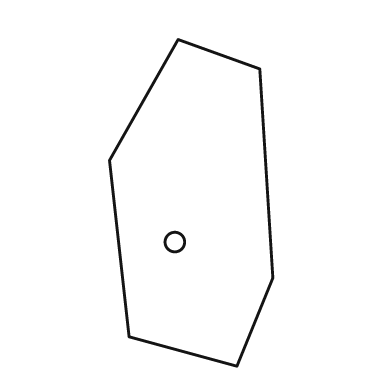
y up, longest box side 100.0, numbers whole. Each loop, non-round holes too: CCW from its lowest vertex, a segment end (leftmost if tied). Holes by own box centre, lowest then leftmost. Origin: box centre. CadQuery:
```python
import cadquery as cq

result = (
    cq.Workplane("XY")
    .moveTo(14.0, -50.0)
    .lineTo(25.0, -23.0)
    .lineTo(21.0, 41.0)
    .lineTo(-4.0, 50.0)
    .lineTo(-25.0, 13.0)
    .lineTo(-19.0, -41.0)
    .close()
    .moveTo(-5.0, -12.0)
    .circle(3.0)
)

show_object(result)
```